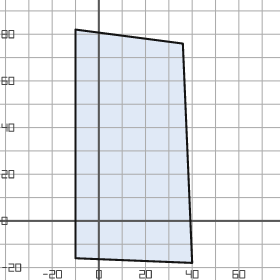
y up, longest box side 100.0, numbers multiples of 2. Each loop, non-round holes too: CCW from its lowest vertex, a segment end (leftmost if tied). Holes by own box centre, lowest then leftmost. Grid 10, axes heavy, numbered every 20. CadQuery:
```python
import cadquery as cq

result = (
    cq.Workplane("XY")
    .moveTo(40.0, -18.0)
    .lineTo(36.0, 76.0)
    .lineTo(-10.0, 82.0)
    .lineTo(-10.0, -16.0)
    .close()
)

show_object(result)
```